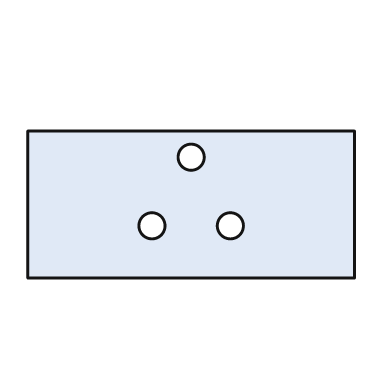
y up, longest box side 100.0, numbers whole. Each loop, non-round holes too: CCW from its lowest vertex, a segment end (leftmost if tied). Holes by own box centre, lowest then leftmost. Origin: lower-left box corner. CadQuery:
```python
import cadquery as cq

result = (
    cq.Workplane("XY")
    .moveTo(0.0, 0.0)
    .lineTo(100.0, 0.0)
    .lineTo(100.0, 45.0)
    .lineTo(0.0, 45.0)
    .close()
    .moveTo(38.0, 16.0)
    .circle(4.0)
    .moveTo(62.0, 16.0)
    .circle(4.0)
    .moveTo(50.0, 37.0)
    .circle(4.0)
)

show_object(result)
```